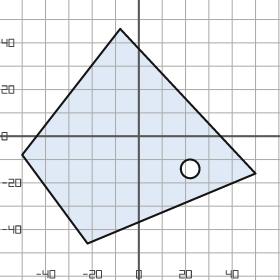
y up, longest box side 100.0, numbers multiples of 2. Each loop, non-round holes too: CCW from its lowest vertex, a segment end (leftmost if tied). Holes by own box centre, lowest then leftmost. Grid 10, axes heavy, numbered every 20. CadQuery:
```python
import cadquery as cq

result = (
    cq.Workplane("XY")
    .moveTo(-22.0, -46.0)
    .lineTo(50.0, -16.0)
    .lineTo(-8.0, 46.0)
    .lineTo(-50.0, -8.0)
    .close()
    .moveTo(22.0, -14.0)
    .circle(4.0)
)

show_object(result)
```